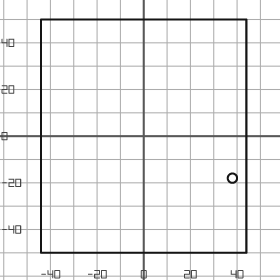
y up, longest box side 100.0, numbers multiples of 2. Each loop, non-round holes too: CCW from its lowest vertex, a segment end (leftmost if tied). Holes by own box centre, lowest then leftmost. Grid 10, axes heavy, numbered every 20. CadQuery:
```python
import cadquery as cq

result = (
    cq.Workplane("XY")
    .moveTo(-44.0, -50.0)
    .lineTo(44.0, -50.0)
    .lineTo(44.0, 50.0)
    .lineTo(-44.0, 50.0)
    .close()
    .moveTo(38.0, -18.0)
    .circle(2.0)
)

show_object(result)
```